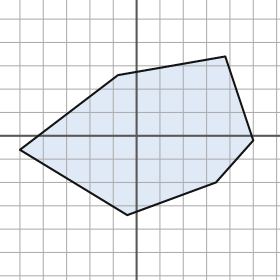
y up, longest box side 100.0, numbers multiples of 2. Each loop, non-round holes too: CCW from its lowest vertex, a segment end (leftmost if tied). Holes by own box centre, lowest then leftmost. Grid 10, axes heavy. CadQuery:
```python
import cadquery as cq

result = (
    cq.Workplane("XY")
    .moveTo(-4.0, -34.0)
    .lineTo(34.0, -20.0)
    .lineTo(50.0, -2.0)
    .lineTo(38.0, 34.0)
    .lineTo(-8.0, 26.0)
    .lineTo(-50.0, -6.0)
    .close()
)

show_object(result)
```